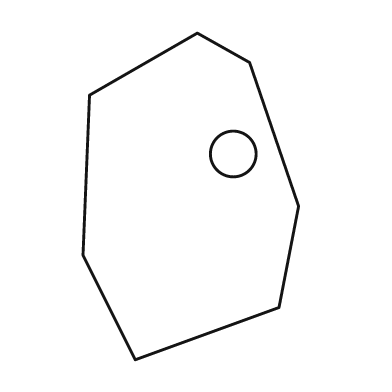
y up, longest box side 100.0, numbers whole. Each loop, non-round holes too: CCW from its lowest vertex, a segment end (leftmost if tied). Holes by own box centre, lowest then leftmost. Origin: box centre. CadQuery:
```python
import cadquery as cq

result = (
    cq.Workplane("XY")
    .moveTo(-17.0, -50.0)
    .lineTo(27.0, -34.0)
    .lineTo(33.0, -3.0)
    .lineTo(18.0, 41.0)
    .lineTo(2.0, 50.0)
    .lineTo(-31.0, 31.0)
    .lineTo(-33.0, -18.0)
    .close()
    .moveTo(13.0, 13.0)
    .circle(7.0)
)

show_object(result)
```